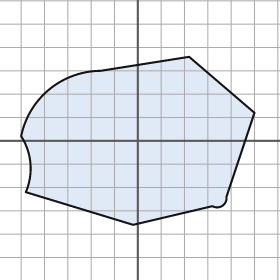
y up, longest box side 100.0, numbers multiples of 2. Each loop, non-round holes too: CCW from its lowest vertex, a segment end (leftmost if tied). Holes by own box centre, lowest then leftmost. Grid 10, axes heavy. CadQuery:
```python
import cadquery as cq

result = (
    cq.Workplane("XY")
    .moveTo(-2.0, -36.0)
    .lineTo(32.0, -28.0)
    .threePointArc((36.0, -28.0), (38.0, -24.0))
    .lineTo(50.0, 12.0)
    .lineTo(22.0, 36.0)
    .lineTo(-16.0, 30.0)
    .threePointArc((-38.0, 22.0), (-50.0, 2.0))
    .threePointArc((-46.0, -10.0), (-48.0, -22.0))
    .close()
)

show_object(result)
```